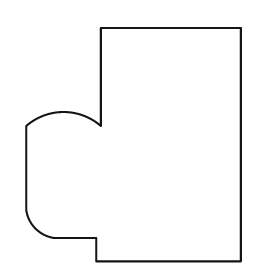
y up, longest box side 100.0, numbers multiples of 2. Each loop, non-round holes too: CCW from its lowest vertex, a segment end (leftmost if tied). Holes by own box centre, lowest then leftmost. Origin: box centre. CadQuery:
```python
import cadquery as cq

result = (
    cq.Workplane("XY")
    .moveTo(-16.0, -50.0)
    .lineTo(46.0, -50.0)
    .lineTo(46.0, 50.0)
    .lineTo(-14.0, 50.0)
    .lineTo(-14.0, 8.0)
    .threePointArc((-30.0, 14.0), (-46.0, 8.0))
    .lineTo(-46.0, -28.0)
    .threePointArc((-42.0, -36.0), (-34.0, -40.0))
    .lineTo(-16.0, -40.0)
    .close()
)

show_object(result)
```